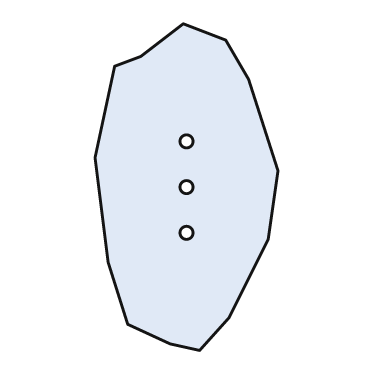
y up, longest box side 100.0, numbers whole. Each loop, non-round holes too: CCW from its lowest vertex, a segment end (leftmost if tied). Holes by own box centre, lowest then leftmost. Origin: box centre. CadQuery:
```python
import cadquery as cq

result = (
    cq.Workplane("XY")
    .moveTo(4.0, -50.0)
    .lineTo(13.0, -40.0)
    .lineTo(25.0, -16.0)
    .lineTo(28.0, 5.0)
    .lineTo(19.0, 33.0)
    .lineTo(12.0, 45.0)
    .lineTo(-1.0, 50.0)
    .lineTo(-14.0, 40.0)
    .lineTo(-22.0, 37.0)
    .lineTo(-28.0, 9.0)
    .lineTo(-24.0, -23.0)
    .lineTo(-18.0, -42.0)
    .lineTo(-5.0, -48.0)
    .close()
    .moveTo(0.0, -14.0)
    .circle(2.0)
    .moveTo(0.0, 0.0)
    .circle(2.0)
    .moveTo(0.0, 14.0)
    .circle(2.0)
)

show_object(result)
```